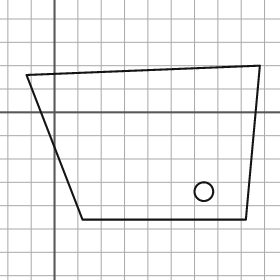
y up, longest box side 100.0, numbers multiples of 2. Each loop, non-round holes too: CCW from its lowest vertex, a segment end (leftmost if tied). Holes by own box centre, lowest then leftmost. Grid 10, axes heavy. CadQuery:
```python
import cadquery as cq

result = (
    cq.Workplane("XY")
    .moveTo(12.0, -46.0)
    .lineTo(82.0, -46.0)
    .lineTo(88.0, 20.0)
    .lineTo(-12.0, 16.0)
    .close()
    .moveTo(64.0, -34.0)
    .circle(4.0)
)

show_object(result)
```